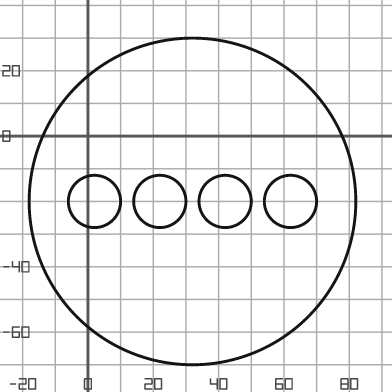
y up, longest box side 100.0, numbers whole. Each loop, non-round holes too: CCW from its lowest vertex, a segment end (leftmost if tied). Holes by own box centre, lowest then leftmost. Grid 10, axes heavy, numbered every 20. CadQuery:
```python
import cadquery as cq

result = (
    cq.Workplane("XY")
    .moveTo(32.0, -20.0)
    .circle(50.0)
    .moveTo(2.0, -20.0)
    .circle(8.0)
    .moveTo(22.0, -20.0)
    .circle(8.0)
    .moveTo(42.0, -20.0)
    .circle(8.0)
    .moveTo(62.0, -20.0)
    .circle(8.0)
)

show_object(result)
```